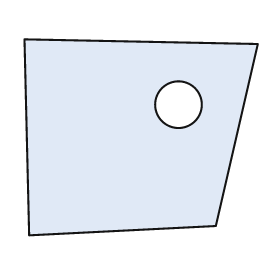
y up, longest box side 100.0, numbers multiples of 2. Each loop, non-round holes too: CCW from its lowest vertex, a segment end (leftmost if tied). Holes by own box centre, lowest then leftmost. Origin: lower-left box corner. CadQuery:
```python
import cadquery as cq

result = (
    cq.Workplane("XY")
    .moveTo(2.0, 0.0)
    .lineTo(82.0, 4.0)
    .lineTo(100.0, 82.0)
    .lineTo(0.0, 84.0)
    .close()
    .moveTo(66.0, 56.0)
    .circle(10.0)
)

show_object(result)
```